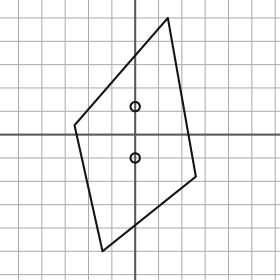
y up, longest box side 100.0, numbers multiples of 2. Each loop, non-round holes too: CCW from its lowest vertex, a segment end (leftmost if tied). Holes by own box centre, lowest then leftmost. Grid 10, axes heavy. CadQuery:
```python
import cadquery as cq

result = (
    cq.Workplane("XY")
    .moveTo(-14.0, -50.0)
    .lineTo(26.0, -18.0)
    .lineTo(14.0, 50.0)
    .lineTo(-26.0, 4.0)
    .close()
    .moveTo(0.0, -10.0)
    .circle(2.0)
    .moveTo(0.0, 12.0)
    .circle(2.0)
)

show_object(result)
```